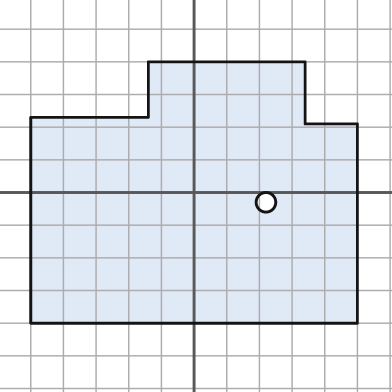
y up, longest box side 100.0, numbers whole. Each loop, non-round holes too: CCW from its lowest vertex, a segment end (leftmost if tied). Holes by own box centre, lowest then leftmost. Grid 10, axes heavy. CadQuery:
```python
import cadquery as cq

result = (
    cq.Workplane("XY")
    .moveTo(-50.0, -40.0)
    .lineTo(50.0, -40.0)
    .lineTo(50.0, 21.0)
    .lineTo(34.0, 21.0)
    .lineTo(34.0, 40.0)
    .lineTo(-14.0, 40.0)
    .lineTo(-14.0, 23.0)
    .lineTo(-50.0, 23.0)
    .close()
    .moveTo(22.0, -3.0)
    .circle(3.0)
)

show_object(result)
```